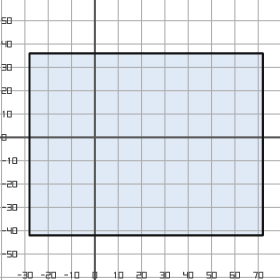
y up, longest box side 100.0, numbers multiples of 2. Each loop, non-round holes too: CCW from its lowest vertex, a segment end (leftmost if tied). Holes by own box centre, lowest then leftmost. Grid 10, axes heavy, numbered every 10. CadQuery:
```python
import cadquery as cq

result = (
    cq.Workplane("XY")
    .moveTo(-28.0, -42.0)
    .lineTo(72.0, -42.0)
    .lineTo(72.0, 36.0)
    .lineTo(-28.0, 36.0)
    .close()
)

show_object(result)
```